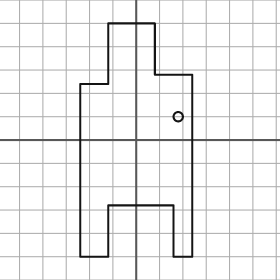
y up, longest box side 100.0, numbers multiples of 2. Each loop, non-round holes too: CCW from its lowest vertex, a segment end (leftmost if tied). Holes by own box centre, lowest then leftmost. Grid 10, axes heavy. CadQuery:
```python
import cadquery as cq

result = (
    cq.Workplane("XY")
    .moveTo(-24.0, -50.0)
    .lineTo(-12.0, -50.0)
    .lineTo(-12.0, -28.0)
    .lineTo(16.0, -28.0)
    .lineTo(16.0, -50.0)
    .lineTo(24.0, -50.0)
    .lineTo(24.0, 28.0)
    .lineTo(8.0, 28.0)
    .lineTo(8.0, 50.0)
    .lineTo(-12.0, 50.0)
    .lineTo(-12.0, 24.0)
    .lineTo(-24.0, 24.0)
    .close()
    .moveTo(18.0, 10.0)
    .circle(2.0)
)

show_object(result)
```